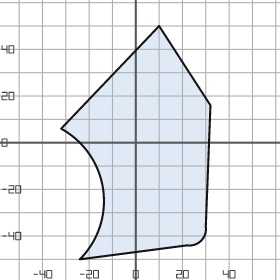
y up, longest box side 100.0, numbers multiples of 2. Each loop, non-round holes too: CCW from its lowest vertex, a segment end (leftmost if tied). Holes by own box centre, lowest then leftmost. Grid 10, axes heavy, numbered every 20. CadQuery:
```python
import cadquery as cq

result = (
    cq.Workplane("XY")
    .moveTo(-24.0, -50.0)
    .lineTo(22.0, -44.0)
    .threePointArc((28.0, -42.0), (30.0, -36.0))
    .lineTo(32.0, 16.0)
    .lineTo(10.0, 50.0)
    .lineTo(-32.0, 6.0)
    .threePointArc((-14.0, -20.0), (-24.0, -50.0))
    .close()
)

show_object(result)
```